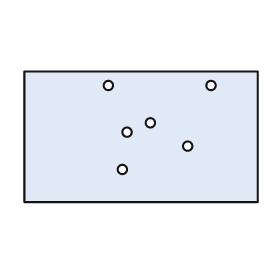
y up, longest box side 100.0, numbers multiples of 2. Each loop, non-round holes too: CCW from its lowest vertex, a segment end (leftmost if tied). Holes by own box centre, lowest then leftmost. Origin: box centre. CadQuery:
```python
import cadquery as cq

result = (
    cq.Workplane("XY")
    .moveTo(-50.0, -28.0)
    .lineTo(50.0, -28.0)
    .lineTo(50.0, 28.0)
    .lineTo(-50.0, 28.0)
    .close()
    .moveTo(-8.0, -14.0)
    .circle(2.0)
    .moveTo(20.0, -4.0)
    .circle(2.0)
    .moveTo(-6.0, 2.0)
    .circle(2.0)
    .moveTo(4.0, 6.0)
    .circle(2.0)
    .moveTo(-14.0, 22.0)
    .circle(2.0)
    .moveTo(30.0, 22.0)
    .circle(2.0)
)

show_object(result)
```